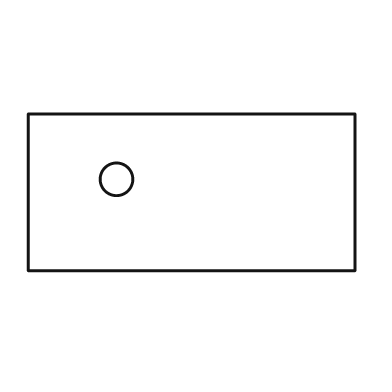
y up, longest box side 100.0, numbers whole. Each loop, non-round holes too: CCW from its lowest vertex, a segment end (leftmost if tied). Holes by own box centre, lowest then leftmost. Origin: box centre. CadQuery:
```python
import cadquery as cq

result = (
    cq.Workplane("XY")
    .moveTo(-50.0, -24.0)
    .lineTo(50.0, -24.0)
    .lineTo(50.0, 24.0)
    .lineTo(-50.0, 24.0)
    .close()
    .moveTo(-23.0, 4.0)
    .circle(5.0)
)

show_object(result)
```